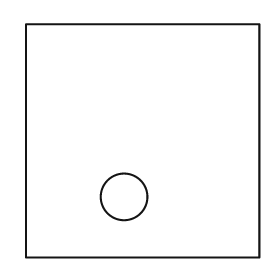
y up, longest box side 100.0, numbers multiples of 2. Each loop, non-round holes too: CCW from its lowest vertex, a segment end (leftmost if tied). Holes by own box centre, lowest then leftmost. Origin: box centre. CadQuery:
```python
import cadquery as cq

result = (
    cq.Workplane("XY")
    .moveTo(-50.0, -50.0)
    .lineTo(50.0, -50.0)
    .lineTo(50.0, 50.0)
    .lineTo(-50.0, 50.0)
    .close()
    .moveTo(-8.0, -24.0)
    .circle(10.0)
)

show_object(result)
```